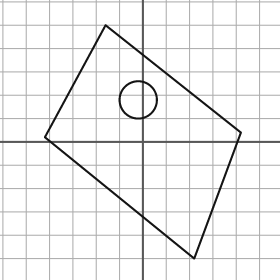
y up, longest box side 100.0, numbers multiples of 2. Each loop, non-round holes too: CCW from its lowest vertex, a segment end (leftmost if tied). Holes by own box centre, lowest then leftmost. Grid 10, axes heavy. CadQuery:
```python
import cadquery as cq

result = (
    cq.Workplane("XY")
    .moveTo(22.0, -50.0)
    .lineTo(42.0, 4.0)
    .lineTo(-16.0, 50.0)
    .lineTo(-42.0, 2.0)
    .close()
    .moveTo(-2.0, 18.0)
    .circle(8.0)
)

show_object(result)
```